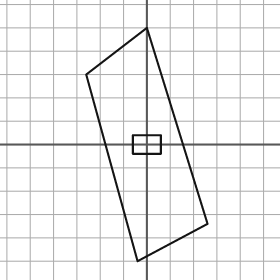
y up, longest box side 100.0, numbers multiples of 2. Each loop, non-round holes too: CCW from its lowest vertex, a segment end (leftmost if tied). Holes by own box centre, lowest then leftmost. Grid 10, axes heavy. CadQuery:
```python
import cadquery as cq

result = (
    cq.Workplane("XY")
    .moveTo(-4.0, -50.0)
    .lineTo(26.0, -34.0)
    .lineTo(0.0, 50.0)
    .lineTo(-26.0, 30.0)
    .close()
    .moveTo(-6.0, -4.0)
    .lineTo(6.0, -4.0)
    .lineTo(6.0, 4.0)
    .lineTo(-6.0, 4.0)
    .close()
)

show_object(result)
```